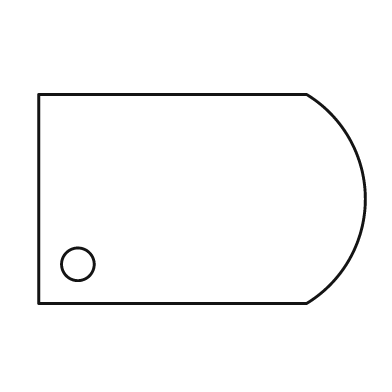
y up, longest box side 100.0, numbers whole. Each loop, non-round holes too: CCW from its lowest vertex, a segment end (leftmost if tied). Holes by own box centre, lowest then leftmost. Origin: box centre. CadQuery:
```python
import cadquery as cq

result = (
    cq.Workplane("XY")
    .moveTo(-50.0, -32.0)
    .lineTo(32.0, -32.0)
    .threePointArc((50.0, 0.0), (32.0, 32.0))
    .lineTo(-50.0, 32.0)
    .close()
    .moveTo(-38.0, -20.0)
    .circle(5.0)
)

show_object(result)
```